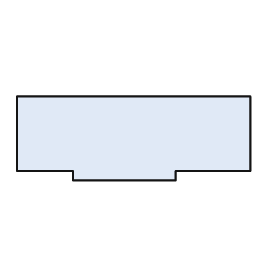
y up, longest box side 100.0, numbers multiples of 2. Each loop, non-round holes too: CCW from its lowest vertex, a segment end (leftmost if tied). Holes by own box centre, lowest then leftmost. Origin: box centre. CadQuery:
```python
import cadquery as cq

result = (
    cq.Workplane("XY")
    .moveTo(-26.0, -18.0)
    .lineTo(18.0, -18.0)
    .lineTo(18.0, -14.0)
    .lineTo(50.0, -14.0)
    .lineTo(50.0, 18.0)
    .lineTo(-50.0, 18.0)
    .lineTo(-50.0, -14.0)
    .lineTo(-26.0, -14.0)
    .close()
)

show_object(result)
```